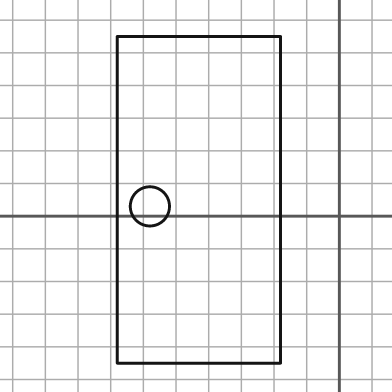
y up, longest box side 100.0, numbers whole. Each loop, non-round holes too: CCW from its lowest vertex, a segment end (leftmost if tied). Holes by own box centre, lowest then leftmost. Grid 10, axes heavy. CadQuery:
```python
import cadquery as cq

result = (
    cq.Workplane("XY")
    .moveTo(-68.0, -45.0)
    .lineTo(-18.0, -45.0)
    .lineTo(-18.0, 55.0)
    .lineTo(-68.0, 55.0)
    .close()
    .moveTo(-58.0, 3.0)
    .circle(6.0)
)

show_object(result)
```